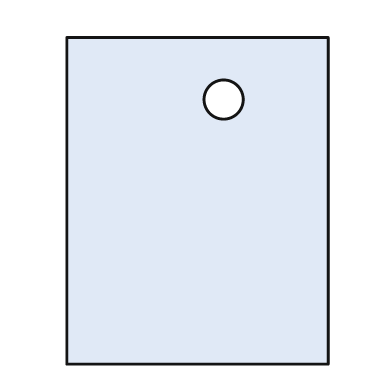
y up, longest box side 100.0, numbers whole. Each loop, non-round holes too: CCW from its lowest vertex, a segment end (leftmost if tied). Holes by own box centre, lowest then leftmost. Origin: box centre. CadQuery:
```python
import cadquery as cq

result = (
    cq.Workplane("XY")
    .moveTo(-40.0, -50.0)
    .lineTo(40.0, -50.0)
    .lineTo(40.0, 50.0)
    .lineTo(-40.0, 50.0)
    .close()
    .moveTo(8.0, 31.0)
    .circle(6.0)
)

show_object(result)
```